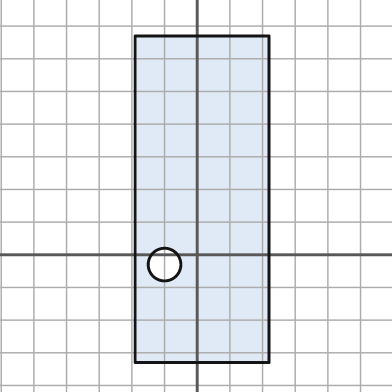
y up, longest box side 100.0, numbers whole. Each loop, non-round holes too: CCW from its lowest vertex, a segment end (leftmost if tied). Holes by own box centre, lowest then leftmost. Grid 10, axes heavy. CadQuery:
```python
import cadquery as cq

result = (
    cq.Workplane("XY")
    .moveTo(-19.0, -33.0)
    .lineTo(22.0, -33.0)
    .lineTo(22.0, 67.0)
    .lineTo(-19.0, 67.0)
    .close()
    .moveTo(-10.0, -3.0)
    .circle(5.0)
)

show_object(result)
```